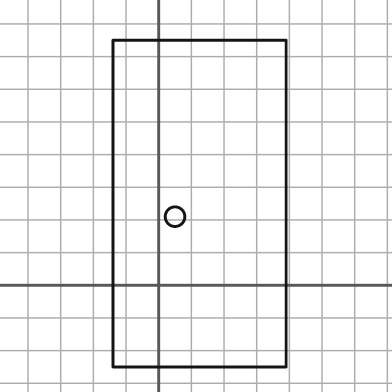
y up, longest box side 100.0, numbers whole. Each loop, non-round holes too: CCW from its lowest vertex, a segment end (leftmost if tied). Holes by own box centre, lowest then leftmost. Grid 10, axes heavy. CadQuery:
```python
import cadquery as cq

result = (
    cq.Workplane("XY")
    .moveTo(-14.0, -25.0)
    .lineTo(39.0, -25.0)
    .lineTo(39.0, 75.0)
    .lineTo(-14.0, 75.0)
    .close()
    .moveTo(5.0, 21.0)
    .circle(3.0)
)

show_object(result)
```